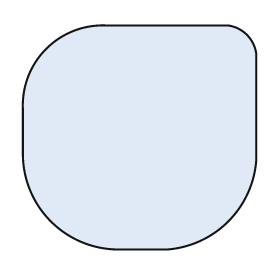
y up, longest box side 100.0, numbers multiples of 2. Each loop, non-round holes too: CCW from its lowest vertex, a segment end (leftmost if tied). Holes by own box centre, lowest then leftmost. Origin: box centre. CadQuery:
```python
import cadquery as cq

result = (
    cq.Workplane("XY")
    .moveTo(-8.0, -48.0)
    .lineTo(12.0, -48.0)
    .threePointArc((38.0, -36.0), (50.0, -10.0))
    .lineTo(50.0, 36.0)
    .threePointArc((46.0, 44.0), (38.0, 48.0))
    .lineTo(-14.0, 48.0)
    .threePointArc((-40.0, 38.0), (-50.0, 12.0))
    .lineTo(-50.0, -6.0)
    .threePointArc((-38.0, -36.0), (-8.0, -48.0))
    .close()
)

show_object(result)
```